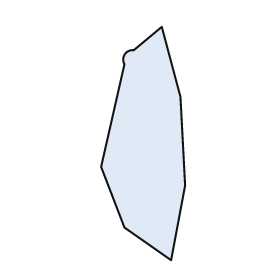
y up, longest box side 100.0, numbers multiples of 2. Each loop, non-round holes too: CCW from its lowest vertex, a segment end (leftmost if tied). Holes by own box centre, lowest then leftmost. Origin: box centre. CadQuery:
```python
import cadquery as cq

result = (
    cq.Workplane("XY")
    .moveTo(12.0, -50.0)
    .lineTo(18.0, -18.0)
    .lineTo(16.0, 20.0)
    .lineTo(8.0, 50.0)
    .lineTo(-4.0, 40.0)
    .threePointArc((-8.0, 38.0), (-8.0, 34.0))
    .lineTo(-18.0, -10.0)
    .lineTo(-8.0, -36.0)
    .close()
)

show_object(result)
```